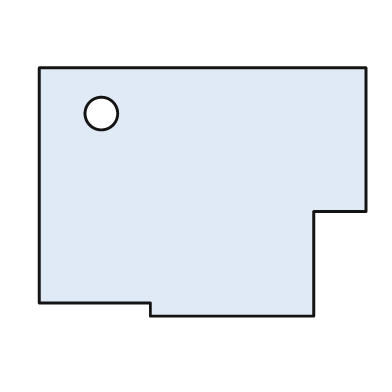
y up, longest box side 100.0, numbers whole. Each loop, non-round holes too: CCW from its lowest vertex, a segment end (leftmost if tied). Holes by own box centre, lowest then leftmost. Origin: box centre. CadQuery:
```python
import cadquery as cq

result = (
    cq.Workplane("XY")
    .moveTo(-16.0, -38.0)
    .lineTo(34.0, -38.0)
    .lineTo(34.0, -6.0)
    .lineTo(50.0, -6.0)
    .lineTo(50.0, 38.0)
    .lineTo(-50.0, 38.0)
    .lineTo(-50.0, -34.0)
    .lineTo(-16.0, -34.0)
    .close()
    .moveTo(-31.0, 24.0)
    .circle(5.0)
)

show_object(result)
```